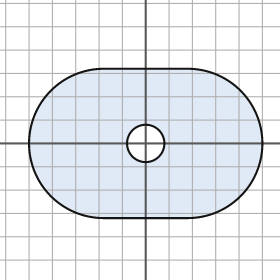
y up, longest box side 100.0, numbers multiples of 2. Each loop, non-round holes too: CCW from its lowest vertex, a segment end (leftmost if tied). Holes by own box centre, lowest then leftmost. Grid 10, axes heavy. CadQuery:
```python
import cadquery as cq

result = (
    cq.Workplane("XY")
    .moveTo(-18.0, -32.0)
    .lineTo(18.0, -32.0)
    .threePointArc((50.0, 0.0), (18.0, 32.0))
    .lineTo(-18.0, 32.0)
    .threePointArc((-50.0, 0.0), (-18.0, -32.0))
    .close()
    .moveTo(0.0, 0.0)
    .circle(8.0)
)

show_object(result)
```